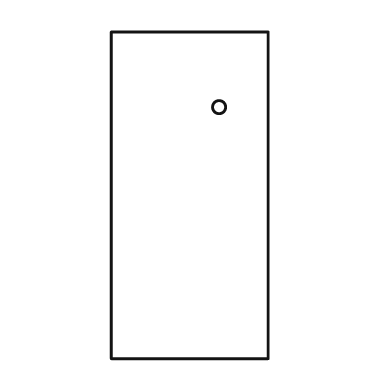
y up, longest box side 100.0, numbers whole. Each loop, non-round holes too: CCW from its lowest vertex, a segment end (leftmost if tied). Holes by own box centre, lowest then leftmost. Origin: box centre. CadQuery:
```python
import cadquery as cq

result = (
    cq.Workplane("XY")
    .moveTo(-24.0, -50.0)
    .lineTo(24.0, -50.0)
    .lineTo(24.0, 50.0)
    .lineTo(-24.0, 50.0)
    .close()
    .moveTo(9.0, 27.0)
    .circle(2.0)
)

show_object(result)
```